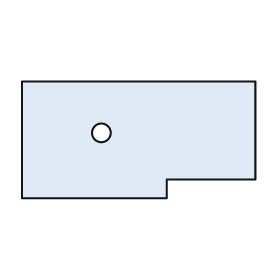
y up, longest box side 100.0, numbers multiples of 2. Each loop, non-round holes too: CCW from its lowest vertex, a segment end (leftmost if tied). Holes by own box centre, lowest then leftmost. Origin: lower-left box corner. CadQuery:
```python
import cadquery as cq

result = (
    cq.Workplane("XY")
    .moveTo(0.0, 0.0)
    .lineTo(62.0, 0.0)
    .lineTo(62.0, 8.0)
    .lineTo(100.0, 8.0)
    .lineTo(100.0, 50.0)
    .lineTo(0.0, 50.0)
    .close()
    .moveTo(34.0, 28.0)
    .circle(4.0)
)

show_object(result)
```